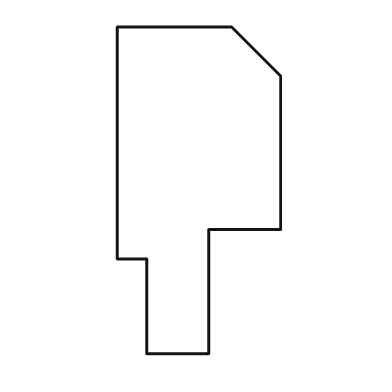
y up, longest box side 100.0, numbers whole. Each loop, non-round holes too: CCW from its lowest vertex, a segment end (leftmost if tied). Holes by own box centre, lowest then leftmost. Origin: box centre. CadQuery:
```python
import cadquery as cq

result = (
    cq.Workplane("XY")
    .moveTo(-16.0, -50.0)
    .lineTo(3.0, -50.0)
    .lineTo(3.0, -12.0)
    .lineTo(25.0, -12.0)
    .lineTo(25.0, 35.0)
    .lineTo(10.0, 50.0)
    .lineTo(-25.0, 50.0)
    .lineTo(-25.0, -21.0)
    .lineTo(-16.0, -21.0)
    .close()
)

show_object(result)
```